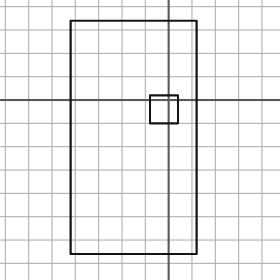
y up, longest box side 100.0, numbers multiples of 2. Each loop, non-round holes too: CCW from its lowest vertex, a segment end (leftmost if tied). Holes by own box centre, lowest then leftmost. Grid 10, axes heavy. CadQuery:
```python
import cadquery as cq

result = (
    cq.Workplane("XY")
    .moveTo(-42.0, -66.0)
    .lineTo(12.0, -66.0)
    .lineTo(12.0, 34.0)
    .lineTo(-42.0, 34.0)
    .close()
    .moveTo(-8.0, -10.0)
    .lineTo(4.0, -10.0)
    .lineTo(4.0, 2.0)
    .lineTo(-8.0, 2.0)
    .close()
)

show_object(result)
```